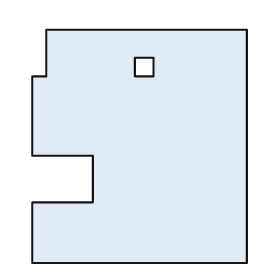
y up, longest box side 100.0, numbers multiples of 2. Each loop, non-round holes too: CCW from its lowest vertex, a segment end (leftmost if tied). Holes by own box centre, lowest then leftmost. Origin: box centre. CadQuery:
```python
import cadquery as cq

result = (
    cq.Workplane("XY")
    .moveTo(-46.0, -50.0)
    .lineTo(46.0, -50.0)
    .lineTo(46.0, 50.0)
    .lineTo(-40.0, 50.0)
    .lineTo(-40.0, 30.0)
    .lineTo(-46.0, 30.0)
    .lineTo(-46.0, -4.0)
    .lineTo(-20.0, -4.0)
    .lineTo(-20.0, -24.0)
    .lineTo(-46.0, -24.0)
    .close()
    .moveTo(-2.0, 30.0)
    .lineTo(6.0, 30.0)
    .lineTo(6.0, 38.0)
    .lineTo(-2.0, 38.0)
    .close()
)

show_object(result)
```